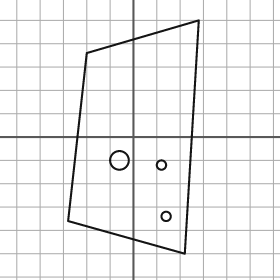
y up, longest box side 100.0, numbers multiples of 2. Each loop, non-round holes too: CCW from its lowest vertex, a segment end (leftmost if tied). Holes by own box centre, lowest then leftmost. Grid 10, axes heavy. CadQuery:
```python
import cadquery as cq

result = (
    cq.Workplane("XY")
    .moveTo(22.0, -50.0)
    .lineTo(28.0, 50.0)
    .lineTo(-20.0, 36.0)
    .lineTo(-28.0, -36.0)
    .close()
    .moveTo(14.0, -34.0)
    .circle(2.0)
    .moveTo(12.0, -12.0)
    .circle(2.0)
    .moveTo(-6.0, -10.0)
    .circle(4.0)
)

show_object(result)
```